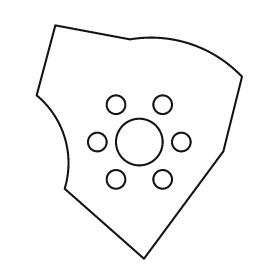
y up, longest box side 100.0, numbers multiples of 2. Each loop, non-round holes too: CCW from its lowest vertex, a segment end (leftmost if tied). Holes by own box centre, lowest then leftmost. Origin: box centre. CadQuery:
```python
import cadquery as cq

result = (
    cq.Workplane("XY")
    .moveTo(2.0, -50.0)
    .lineTo(36.0, -4.0)
    .lineTo(44.0, 28.0)
    .threePointArc((22.0, 42.0), (-4.0, 44.0))
    .lineTo(-36.0, 50.0)
    .lineTo(-44.0, 20.0)
    .threePointArc((-32.0, 2.0), (-32.0, -20.0))
    .close()
    .moveTo(-10.0, -16.0)
    .circle(4.0)
    .moveTo(10.0, -16.0)
    .circle(4.0)
    .moveTo(-18.0, 0.0)
    .circle(4.0)
    .moveTo(0.0, 0.0)
    .circle(10.0)
    .moveTo(18.0, 0.0)
    .circle(4.0)
    .moveTo(-10.0, 16.0)
    .circle(4.0)
    .moveTo(10.0, 16.0)
    .circle(4.0)
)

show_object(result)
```